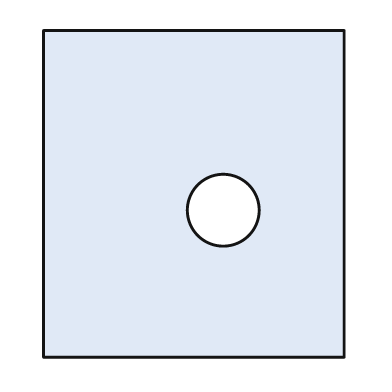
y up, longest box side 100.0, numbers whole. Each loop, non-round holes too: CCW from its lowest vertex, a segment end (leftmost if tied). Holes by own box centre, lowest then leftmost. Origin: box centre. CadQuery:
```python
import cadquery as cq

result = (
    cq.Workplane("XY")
    .moveTo(-46.0, -50.0)
    .lineTo(46.0, -50.0)
    .lineTo(46.0, 50.0)
    .lineTo(-46.0, 50.0)
    .close()
    .moveTo(9.0, -5.0)
    .circle(11.0)
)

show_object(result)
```